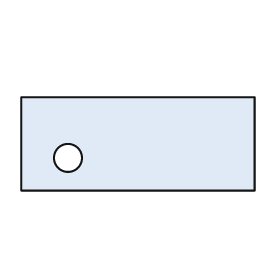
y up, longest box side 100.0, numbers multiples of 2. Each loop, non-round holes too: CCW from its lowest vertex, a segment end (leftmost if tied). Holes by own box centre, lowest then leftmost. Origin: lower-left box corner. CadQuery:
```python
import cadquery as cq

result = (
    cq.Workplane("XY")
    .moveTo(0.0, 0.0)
    .lineTo(100.0, 0.0)
    .lineTo(100.0, 40.0)
    .lineTo(0.0, 40.0)
    .close()
    .moveTo(20.0, 14.0)
    .circle(6.0)
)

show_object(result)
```